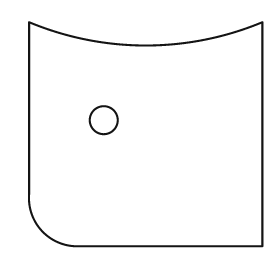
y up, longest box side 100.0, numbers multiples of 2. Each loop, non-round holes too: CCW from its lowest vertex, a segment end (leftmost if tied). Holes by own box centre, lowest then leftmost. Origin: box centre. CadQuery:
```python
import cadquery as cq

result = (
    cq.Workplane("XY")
    .moveTo(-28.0, -48.0)
    .lineTo(50.0, -48.0)
    .lineTo(50.0, 48.0)
    .threePointArc((0.0, 38.0), (-50.0, 48.0))
    .lineTo(-50.0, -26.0)
    .threePointArc((-44.0, -42.0), (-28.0, -48.0))
    .close()
    .moveTo(-18.0, 6.0)
    .circle(6.0)
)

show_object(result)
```